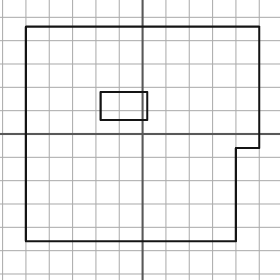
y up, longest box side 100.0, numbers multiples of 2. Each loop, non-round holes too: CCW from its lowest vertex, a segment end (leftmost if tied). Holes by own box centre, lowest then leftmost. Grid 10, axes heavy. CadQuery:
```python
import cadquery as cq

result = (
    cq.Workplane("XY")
    .moveTo(-50.0, -46.0)
    .lineTo(40.0, -46.0)
    .lineTo(40.0, -6.0)
    .lineTo(50.0, -6.0)
    .lineTo(50.0, 46.0)
    .lineTo(-50.0, 46.0)
    .close()
    .moveTo(-18.0, 6.0)
    .lineTo(2.0, 6.0)
    .lineTo(2.0, 18.0)
    .lineTo(-18.0, 18.0)
    .close()
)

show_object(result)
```